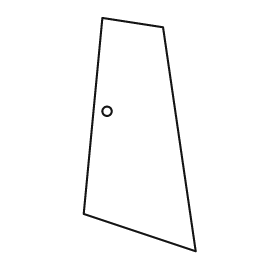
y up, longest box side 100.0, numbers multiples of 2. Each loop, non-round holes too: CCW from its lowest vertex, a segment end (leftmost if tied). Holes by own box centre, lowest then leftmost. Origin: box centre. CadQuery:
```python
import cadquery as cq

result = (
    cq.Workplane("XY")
    .moveTo(24.0, -50.0)
    .lineTo(10.0, 46.0)
    .lineTo(-16.0, 50.0)
    .lineTo(-24.0, -34.0)
    .close()
    .moveTo(-14.0, 10.0)
    .circle(2.0)
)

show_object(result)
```